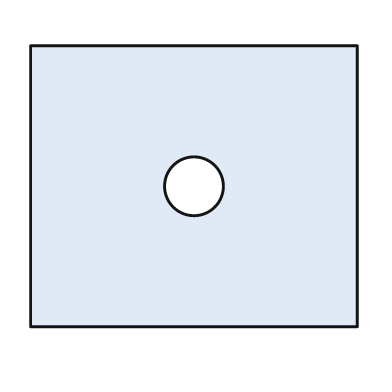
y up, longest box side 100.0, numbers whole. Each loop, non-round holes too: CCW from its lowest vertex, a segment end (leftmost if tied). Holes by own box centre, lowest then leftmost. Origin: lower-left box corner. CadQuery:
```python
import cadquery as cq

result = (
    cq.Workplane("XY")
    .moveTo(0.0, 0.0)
    .lineTo(100.0, 0.0)
    .lineTo(100.0, 86.0)
    .lineTo(0.0, 86.0)
    .close()
    .moveTo(50.0, 43.0)
    .circle(9.0)
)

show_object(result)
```